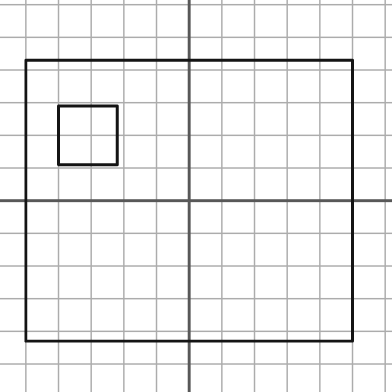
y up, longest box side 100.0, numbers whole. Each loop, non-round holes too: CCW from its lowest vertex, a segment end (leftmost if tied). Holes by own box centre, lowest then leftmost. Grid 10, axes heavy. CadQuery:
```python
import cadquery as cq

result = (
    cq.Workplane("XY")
    .moveTo(-50.0, -43.0)
    .lineTo(50.0, -43.0)
    .lineTo(50.0, 43.0)
    .lineTo(-50.0, 43.0)
    .close()
    .moveTo(-40.0, 11.0)
    .lineTo(-22.0, 11.0)
    .lineTo(-22.0, 29.0)
    .lineTo(-40.0, 29.0)
    .close()
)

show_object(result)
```